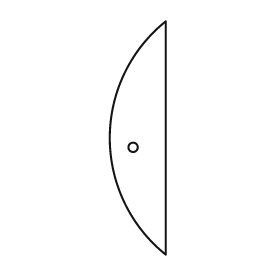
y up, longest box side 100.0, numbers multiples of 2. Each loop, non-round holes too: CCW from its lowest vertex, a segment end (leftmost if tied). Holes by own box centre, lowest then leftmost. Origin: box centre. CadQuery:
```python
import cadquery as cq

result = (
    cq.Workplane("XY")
    .moveTo(12.0, -50.0)
    .lineTo(12.0, 50.0)
    .threePointArc((-12.0, 0.0), (12.0, -50.0))
    .close()
    .moveTo(-2.0, -4.0)
    .circle(2.0)
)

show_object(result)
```